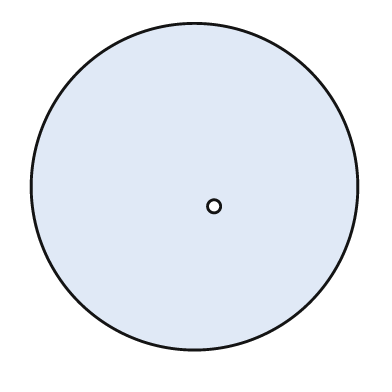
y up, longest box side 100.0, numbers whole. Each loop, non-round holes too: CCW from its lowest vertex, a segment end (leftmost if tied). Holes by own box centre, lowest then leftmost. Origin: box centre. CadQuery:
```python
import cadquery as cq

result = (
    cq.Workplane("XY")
    .moveTo(0.0, 0.0)
    .circle(50.0)
    .moveTo(6.0, -6.0)
    .circle(2.0)
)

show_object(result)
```